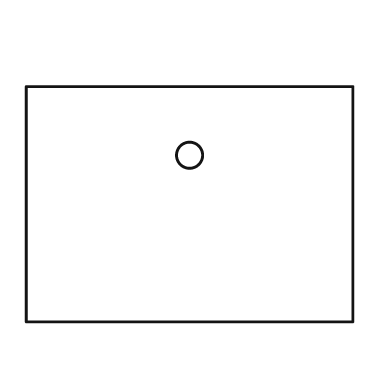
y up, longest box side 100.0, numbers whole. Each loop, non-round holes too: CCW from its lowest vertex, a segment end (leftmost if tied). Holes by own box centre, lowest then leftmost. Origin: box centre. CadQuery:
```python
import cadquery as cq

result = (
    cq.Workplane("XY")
    .moveTo(-50.0, -36.0)
    .lineTo(50.0, -36.0)
    .lineTo(50.0, 36.0)
    .lineTo(-50.0, 36.0)
    .close()
    .moveTo(0.0, 15.0)
    .circle(4.0)
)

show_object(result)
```